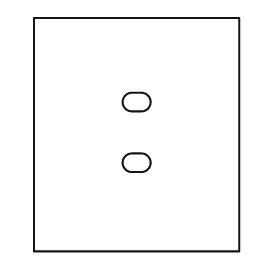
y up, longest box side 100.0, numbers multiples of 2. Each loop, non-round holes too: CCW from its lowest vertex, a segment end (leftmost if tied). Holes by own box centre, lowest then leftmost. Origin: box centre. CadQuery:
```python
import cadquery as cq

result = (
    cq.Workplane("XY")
    .moveTo(-44.0, -50.0)
    .lineTo(44.0, -50.0)
    .lineTo(44.0, 50.0)
    .lineTo(-44.0, 50.0)
    .close()
    .moveTo(-2.0, -16.0)
    .lineTo(2.0, -16.0)
    .threePointArc((6.0, -12.0), (2.0, -8.0))
    .lineTo(-2.0, -8.0)
    .threePointArc((-6.0, -12.0), (-2.0, -16.0))
    .close()
    .moveTo(-2.0, 10.0)
    .lineTo(2.0, 10.0)
    .threePointArc((6.0, 14.0), (2.0, 18.0))
    .lineTo(-2.0, 18.0)
    .threePointArc((-6.0, 14.0), (-2.0, 10.0))
    .close()
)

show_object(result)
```